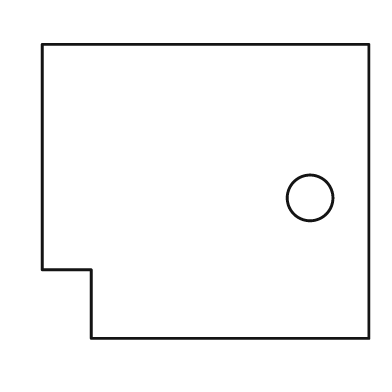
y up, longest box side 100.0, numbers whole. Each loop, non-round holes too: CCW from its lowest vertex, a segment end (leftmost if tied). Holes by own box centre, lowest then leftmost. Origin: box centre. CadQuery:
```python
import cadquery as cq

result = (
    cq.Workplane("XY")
    .moveTo(-35.0, -45.0)
    .lineTo(50.0, -45.0)
    .lineTo(50.0, 45.0)
    .lineTo(-50.0, 45.0)
    .lineTo(-50.0, -24.0)
    .lineTo(-35.0, -24.0)
    .close()
    .moveTo(32.0, -2.0)
    .circle(7.0)
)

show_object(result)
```